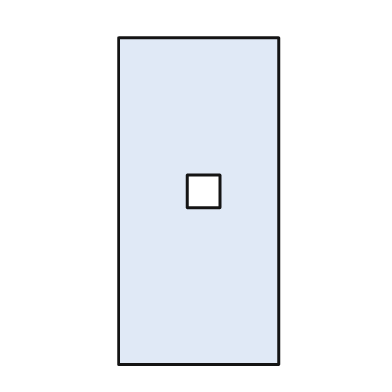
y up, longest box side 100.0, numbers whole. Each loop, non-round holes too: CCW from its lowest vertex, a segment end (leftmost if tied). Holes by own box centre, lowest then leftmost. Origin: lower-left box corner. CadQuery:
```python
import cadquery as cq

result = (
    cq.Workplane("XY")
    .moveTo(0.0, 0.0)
    .lineTo(49.0, 0.0)
    .lineTo(49.0, 100.0)
    .lineTo(0.0, 100.0)
    .close()
    .moveTo(21.0, 48.0)
    .lineTo(31.0, 48.0)
    .lineTo(31.0, 58.0)
    .lineTo(21.0, 58.0)
    .close()
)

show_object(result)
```